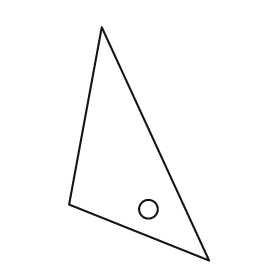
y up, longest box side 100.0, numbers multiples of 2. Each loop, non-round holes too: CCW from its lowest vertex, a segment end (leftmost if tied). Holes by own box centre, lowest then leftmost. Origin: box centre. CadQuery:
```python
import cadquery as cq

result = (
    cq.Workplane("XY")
    .moveTo(30.0, -50.0)
    .lineTo(-16.0, 50.0)
    .lineTo(-30.0, -26.0)
    .close()
    .moveTo(4.0, -28.0)
    .circle(4.0)
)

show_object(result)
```